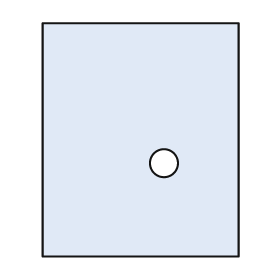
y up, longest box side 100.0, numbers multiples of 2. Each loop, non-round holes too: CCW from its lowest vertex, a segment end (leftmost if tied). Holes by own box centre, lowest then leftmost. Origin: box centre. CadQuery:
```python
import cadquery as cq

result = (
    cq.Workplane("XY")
    .moveTo(-42.0, -50.0)
    .lineTo(42.0, -50.0)
    .lineTo(42.0, 50.0)
    .lineTo(-42.0, 50.0)
    .close()
    .moveTo(10.0, -10.0)
    .circle(6.0)
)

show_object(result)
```